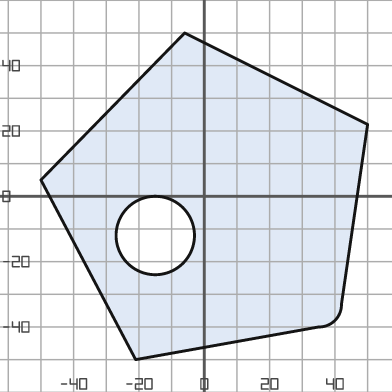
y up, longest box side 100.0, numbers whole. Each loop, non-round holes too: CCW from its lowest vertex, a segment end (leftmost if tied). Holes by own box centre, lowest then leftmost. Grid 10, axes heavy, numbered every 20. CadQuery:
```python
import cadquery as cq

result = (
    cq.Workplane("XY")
    .moveTo(-21.0, -50.0)
    .lineTo(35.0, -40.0)
    .threePointArc((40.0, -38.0), (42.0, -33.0))
    .lineTo(50.0, 22.0)
    .lineTo(-6.0, 50.0)
    .lineTo(-50.0, 5.0)
    .close()
    .moveTo(-15.0, -12.0)
    .circle(12.0)
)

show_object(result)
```